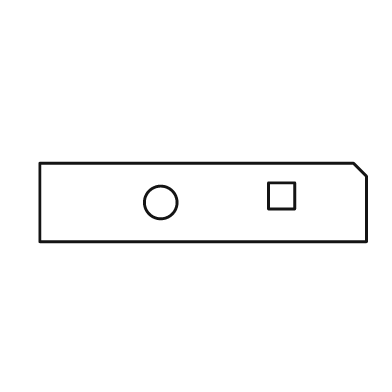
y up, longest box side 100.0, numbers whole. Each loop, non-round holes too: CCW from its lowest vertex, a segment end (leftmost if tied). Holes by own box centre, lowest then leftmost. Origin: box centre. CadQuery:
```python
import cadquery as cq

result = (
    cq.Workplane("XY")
    .moveTo(-50.0, -12.0)
    .lineTo(50.0, -12.0)
    .lineTo(50.0, 8.0)
    .lineTo(46.0, 12.0)
    .lineTo(-50.0, 12.0)
    .close()
    .moveTo(-13.0, 0.0)
    .circle(5.0)
    .moveTo(20.0, -2.0)
    .lineTo(28.0, -2.0)
    .lineTo(28.0, 6.0)
    .lineTo(20.0, 6.0)
    .close()
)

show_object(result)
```